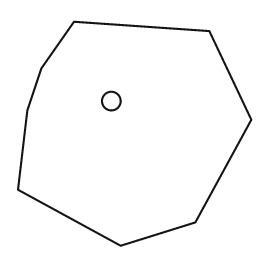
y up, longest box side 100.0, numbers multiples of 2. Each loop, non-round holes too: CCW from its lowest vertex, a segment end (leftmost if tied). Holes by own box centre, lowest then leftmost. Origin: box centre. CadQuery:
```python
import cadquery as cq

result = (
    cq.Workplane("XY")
    .moveTo(-6.0, -48.0)
    .lineTo(26.0, -38.0)
    .lineTo(50.0, 6.0)
    .lineTo(32.0, 44.0)
    .lineTo(-26.0, 48.0)
    .lineTo(-40.0, 28.0)
    .lineTo(-46.0, 10.0)
    .lineTo(-50.0, -24.0)
    .close()
    .moveTo(-10.0, 14.0)
    .circle(4.0)
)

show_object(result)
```